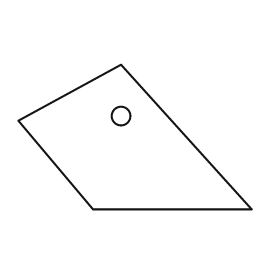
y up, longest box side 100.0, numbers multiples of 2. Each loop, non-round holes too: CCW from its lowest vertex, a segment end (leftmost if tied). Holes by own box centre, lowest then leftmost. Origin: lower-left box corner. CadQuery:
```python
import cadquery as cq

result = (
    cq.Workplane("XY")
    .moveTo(32.0, 0.0)
    .lineTo(100.0, 0.0)
    .lineTo(44.0, 62.0)
    .lineTo(0.0, 38.0)
    .close()
    .moveTo(44.0, 40.0)
    .circle(4.0)
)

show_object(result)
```